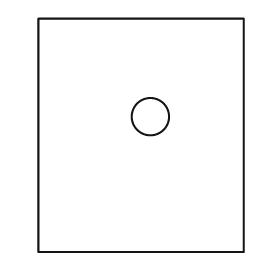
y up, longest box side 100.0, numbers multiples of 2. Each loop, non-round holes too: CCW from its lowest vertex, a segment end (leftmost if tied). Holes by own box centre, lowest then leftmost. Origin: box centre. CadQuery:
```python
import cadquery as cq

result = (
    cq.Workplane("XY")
    .moveTo(-44.0, -50.0)
    .lineTo(44.0, -50.0)
    .lineTo(44.0, 50.0)
    .lineTo(-44.0, 50.0)
    .close()
    .moveTo(4.0, 8.0)
    .circle(8.0)
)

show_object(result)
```